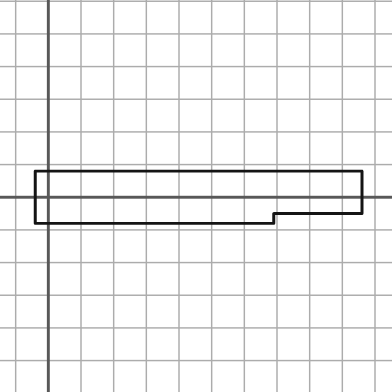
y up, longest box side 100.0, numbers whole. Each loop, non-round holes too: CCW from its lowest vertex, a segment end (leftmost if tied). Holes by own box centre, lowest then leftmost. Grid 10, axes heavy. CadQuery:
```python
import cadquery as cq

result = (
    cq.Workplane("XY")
    .moveTo(-4.0, -8.0)
    .lineTo(69.0, -8.0)
    .lineTo(69.0, -5.0)
    .lineTo(96.0, -5.0)
    .lineTo(96.0, 8.0)
    .lineTo(-4.0, 8.0)
    .close()
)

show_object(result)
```